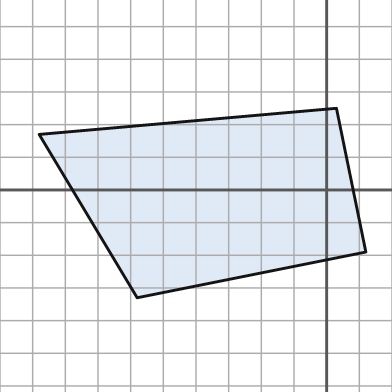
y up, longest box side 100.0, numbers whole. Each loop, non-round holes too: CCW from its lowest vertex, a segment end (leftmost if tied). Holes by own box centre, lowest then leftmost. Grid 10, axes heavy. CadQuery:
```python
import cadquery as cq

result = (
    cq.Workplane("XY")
    .moveTo(-58.0, -33.0)
    .lineTo(12.0, -19.0)
    .lineTo(3.0, 25.0)
    .lineTo(-88.0, 17.0)
    .close()
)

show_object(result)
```